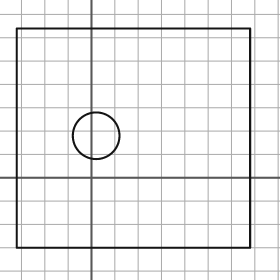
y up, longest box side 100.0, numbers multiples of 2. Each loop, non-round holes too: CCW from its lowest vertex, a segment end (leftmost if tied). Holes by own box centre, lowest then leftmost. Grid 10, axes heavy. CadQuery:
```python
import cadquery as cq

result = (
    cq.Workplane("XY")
    .moveTo(-32.0, -30.0)
    .lineTo(68.0, -30.0)
    .lineTo(68.0, 64.0)
    .lineTo(-32.0, 64.0)
    .close()
    .moveTo(2.0, 18.0)
    .circle(10.0)
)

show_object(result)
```